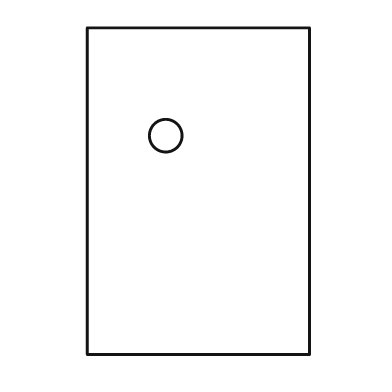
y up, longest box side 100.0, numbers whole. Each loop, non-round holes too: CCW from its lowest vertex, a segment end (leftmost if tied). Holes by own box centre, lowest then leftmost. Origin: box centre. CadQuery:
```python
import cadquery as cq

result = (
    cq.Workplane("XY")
    .moveTo(-34.0, -50.0)
    .lineTo(34.0, -50.0)
    .lineTo(34.0, 50.0)
    .lineTo(-34.0, 50.0)
    .close()
    .moveTo(-10.0, 17.0)
    .circle(5.0)
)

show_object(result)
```